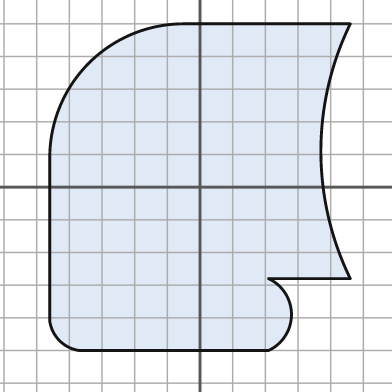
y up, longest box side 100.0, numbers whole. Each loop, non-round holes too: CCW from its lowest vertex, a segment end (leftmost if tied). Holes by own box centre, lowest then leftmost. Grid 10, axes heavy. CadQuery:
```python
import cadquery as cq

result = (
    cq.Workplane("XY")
    .moveTo(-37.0, -50.0)
    .lineTo(21.0, -50.0)
    .threePointArc((28.0, -39.0), (21.0, -28.0))
    .lineTo(46.0, -28.0)
    .threePointArc((37.0, 11.0), (46.0, 50.0))
    .lineTo(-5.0, 50.0)
    .threePointArc((-34.0, 38.0), (-46.0, 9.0))
    .lineTo(-46.0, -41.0)
    .threePointArc((-43.0, -47.0), (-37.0, -50.0))
    .close()
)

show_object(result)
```